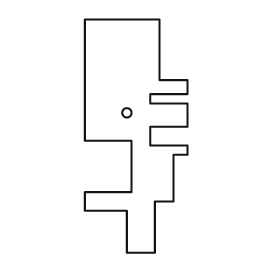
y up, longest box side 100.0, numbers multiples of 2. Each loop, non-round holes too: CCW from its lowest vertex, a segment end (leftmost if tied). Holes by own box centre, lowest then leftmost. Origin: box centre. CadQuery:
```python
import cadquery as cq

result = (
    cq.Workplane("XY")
    .moveTo(-4.0, -50.0)
    .lineTo(8.0, -50.0)
    .lineTo(8.0, -28.0)
    .lineTo(16.0, -28.0)
    .lineTo(16.0, -8.0)
    .lineTo(22.0, -8.0)
    .lineTo(22.0, -4.0)
    .lineTo(6.0, -4.0)
    .lineTo(6.0, 4.0)
    .lineTo(22.0, 4.0)
    .lineTo(22.0, 14.0)
    .lineTo(6.0, 14.0)
    .lineTo(6.0, 18.0)
    .lineTo(22.0, 18.0)
    .lineTo(22.0, 24.0)
    .lineTo(10.0, 24.0)
    .lineTo(10.0, 50.0)
    .lineTo(-22.0, 50.0)
    .lineTo(-22.0, -2.0)
    .lineTo(-2.0, -2.0)
    .lineTo(-2.0, -24.0)
    .lineTo(-22.0, -24.0)
    .lineTo(-22.0, -32.0)
    .lineTo(-4.0, -32.0)
    .close()
    .moveTo(-4.0, 10.0)
    .circle(2.0)
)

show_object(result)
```